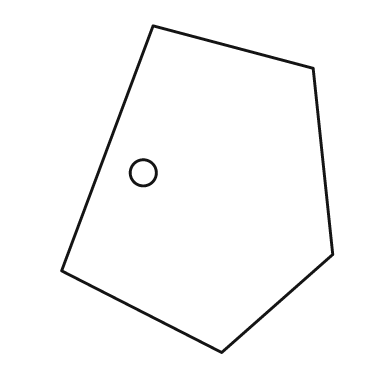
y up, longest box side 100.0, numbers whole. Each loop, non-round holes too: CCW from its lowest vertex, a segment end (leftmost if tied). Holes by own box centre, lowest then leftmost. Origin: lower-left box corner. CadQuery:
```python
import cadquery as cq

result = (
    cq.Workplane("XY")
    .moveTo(49.0, 0.0)
    .lineTo(83.0, 30.0)
    .lineTo(77.0, 87.0)
    .lineTo(28.0, 100.0)
    .lineTo(0.0, 25.0)
    .close()
    .moveTo(25.0, 55.0)
    .circle(4.0)
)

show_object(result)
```